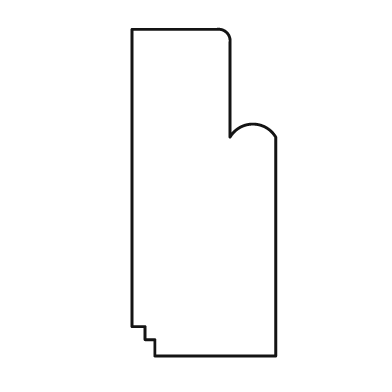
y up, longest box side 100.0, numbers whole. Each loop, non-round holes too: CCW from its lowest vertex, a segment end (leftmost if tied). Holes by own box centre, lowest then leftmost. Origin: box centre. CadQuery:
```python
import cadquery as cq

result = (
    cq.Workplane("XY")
    .moveTo(-15.0, -50.0)
    .lineTo(22.0, -50.0)
    .lineTo(22.0, 17.0)
    .threePointArc((15.0, 21.0), (8.0, 17.0))
    .lineTo(8.0, 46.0)
    .threePointArc((7.0, 49.0), (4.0, 50.0))
    .lineTo(-22.0, 50.0)
    .lineTo(-22.0, -41.0)
    .lineTo(-18.0, -41.0)
    .lineTo(-18.0, -45.0)
    .lineTo(-15.0, -45.0)
    .close()
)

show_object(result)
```